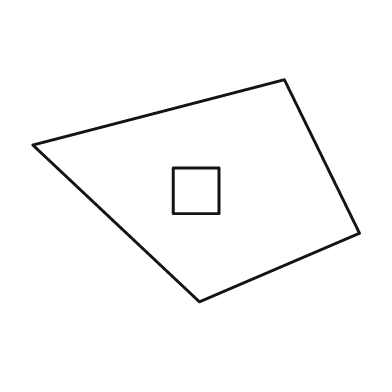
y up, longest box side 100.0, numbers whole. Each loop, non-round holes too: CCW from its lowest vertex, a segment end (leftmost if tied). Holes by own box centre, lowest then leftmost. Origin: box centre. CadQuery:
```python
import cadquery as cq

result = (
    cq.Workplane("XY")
    .moveTo(1.0, -34.0)
    .lineTo(50.0, -13.0)
    .lineTo(27.0, 34.0)
    .lineTo(-50.0, 14.0)
    .close()
    .moveTo(-7.0, -7.0)
    .lineTo(7.0, -7.0)
    .lineTo(7.0, 7.0)
    .lineTo(-7.0, 7.0)
    .close()
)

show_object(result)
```